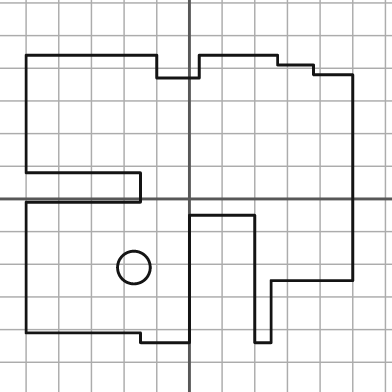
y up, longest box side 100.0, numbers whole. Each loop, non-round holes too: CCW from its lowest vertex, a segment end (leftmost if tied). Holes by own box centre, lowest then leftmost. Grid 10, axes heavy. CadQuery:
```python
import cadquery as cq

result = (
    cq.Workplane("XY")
    .moveTo(-15.0, -44.0)
    .lineTo(0.0, -44.0)
    .lineTo(0.0, -5.0)
    .lineTo(20.0, -5.0)
    .lineTo(20.0, -44.0)
    .lineTo(25.0, -44.0)
    .lineTo(25.0, -25.0)
    .lineTo(50.0, -25.0)
    .lineTo(50.0, 38.0)
    .lineTo(38.0, 38.0)
    .lineTo(38.0, 41.0)
    .lineTo(27.0, 41.0)
    .lineTo(27.0, 44.0)
    .lineTo(3.0, 44.0)
    .lineTo(3.0, 37.0)
    .lineTo(-10.0, 37.0)
    .lineTo(-10.0, 44.0)
    .lineTo(-50.0, 44.0)
    .lineTo(-50.0, 8.0)
    .lineTo(-15.0, 8.0)
    .lineTo(-15.0, -1.0)
    .lineTo(-50.0, -1.0)
    .lineTo(-50.0, -41.0)
    .lineTo(-15.0, -41.0)
    .close()
    .moveTo(-17.0, -21.0)
    .circle(5.0)
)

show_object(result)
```